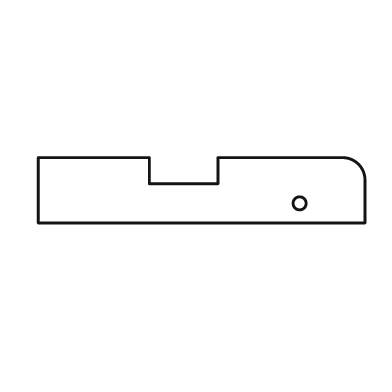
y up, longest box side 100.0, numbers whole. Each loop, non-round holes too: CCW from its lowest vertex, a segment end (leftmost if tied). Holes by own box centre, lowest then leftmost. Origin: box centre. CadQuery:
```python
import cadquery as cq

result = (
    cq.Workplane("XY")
    .moveTo(-50.0, -10.0)
    .lineTo(50.0, -10.0)
    .lineTo(50.0, 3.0)
    .threePointArc((48.0, 8.0), (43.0, 10.0))
    .lineTo(5.0, 10.0)
    .lineTo(5.0, 2.0)
    .lineTo(-16.0, 2.0)
    .lineTo(-16.0, 10.0)
    .lineTo(-50.0, 10.0)
    .close()
    .moveTo(30.0, -4.0)
    .circle(2.0)
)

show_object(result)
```